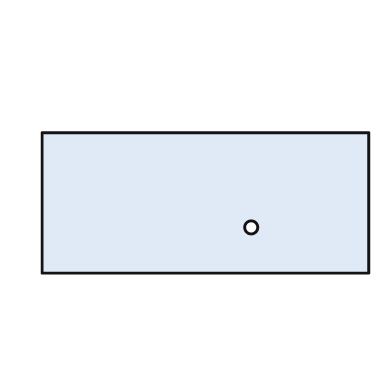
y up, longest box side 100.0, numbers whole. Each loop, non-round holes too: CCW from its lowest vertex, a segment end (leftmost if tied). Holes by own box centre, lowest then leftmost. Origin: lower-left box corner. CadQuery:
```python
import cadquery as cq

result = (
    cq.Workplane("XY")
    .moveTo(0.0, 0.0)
    .lineTo(100.0, 0.0)
    .lineTo(100.0, 43.0)
    .lineTo(0.0, 43.0)
    .close()
    .moveTo(64.0, 14.0)
    .circle(2.0)
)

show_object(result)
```